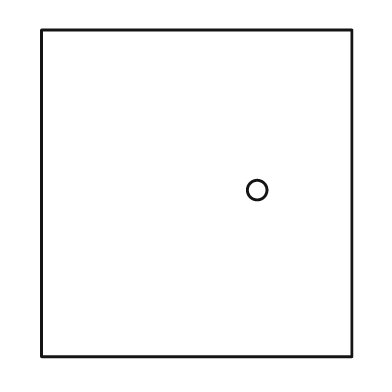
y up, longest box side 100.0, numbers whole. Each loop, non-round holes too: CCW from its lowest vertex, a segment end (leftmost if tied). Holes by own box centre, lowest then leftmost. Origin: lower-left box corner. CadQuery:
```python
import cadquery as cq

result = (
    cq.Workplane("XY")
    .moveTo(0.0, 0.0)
    .lineTo(95.0, 0.0)
    .lineTo(95.0, 100.0)
    .lineTo(0.0, 100.0)
    .close()
    .moveTo(66.0, 51.0)
    .circle(3.0)
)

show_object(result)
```